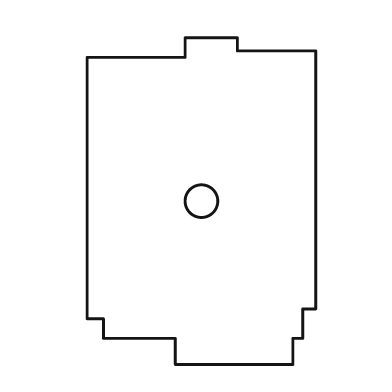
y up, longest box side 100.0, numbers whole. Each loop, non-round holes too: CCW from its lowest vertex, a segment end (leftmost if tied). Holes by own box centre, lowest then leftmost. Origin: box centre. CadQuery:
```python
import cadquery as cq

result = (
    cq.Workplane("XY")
    .moveTo(-8.0, -50.0)
    .lineTo(28.0, -50.0)
    .lineTo(28.0, -42.0)
    .lineTo(31.0, -42.0)
    .lineTo(31.0, -33.0)
    .lineTo(35.0, -33.0)
    .lineTo(35.0, 46.0)
    .lineTo(11.0, 46.0)
    .lineTo(11.0, 50.0)
    .lineTo(-5.0, 50.0)
    .lineTo(-5.0, 44.0)
    .lineTo(-35.0, 44.0)
    .lineTo(-35.0, -36.0)
    .lineTo(-30.0, -36.0)
    .lineTo(-30.0, -42.0)
    .lineTo(-8.0, -42.0)
    .close()
    .moveTo(0.0, 0.0)
    .circle(5.0)
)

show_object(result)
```